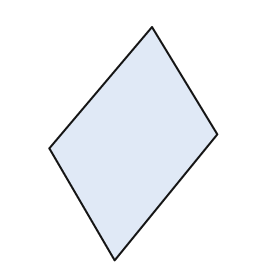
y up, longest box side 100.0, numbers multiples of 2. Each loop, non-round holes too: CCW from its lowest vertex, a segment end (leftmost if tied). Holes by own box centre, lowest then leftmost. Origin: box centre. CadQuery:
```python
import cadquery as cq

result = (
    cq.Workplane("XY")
    .moveTo(-8.0, -50.0)
    .lineTo(36.0, 4.0)
    .lineTo(8.0, 50.0)
    .lineTo(-36.0, -2.0)
    .close()
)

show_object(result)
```